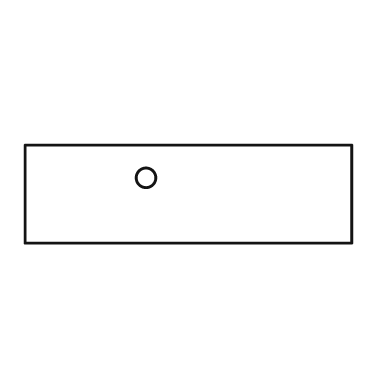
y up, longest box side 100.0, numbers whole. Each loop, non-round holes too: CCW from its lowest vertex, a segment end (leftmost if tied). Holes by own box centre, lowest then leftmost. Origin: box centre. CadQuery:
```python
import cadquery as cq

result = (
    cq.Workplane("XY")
    .moveTo(-50.0, -15.0)
    .lineTo(50.0, -15.0)
    .lineTo(50.0, 15.0)
    .lineTo(-50.0, 15.0)
    .close()
    .moveTo(-13.0, 5.0)
    .circle(3.0)
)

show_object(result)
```